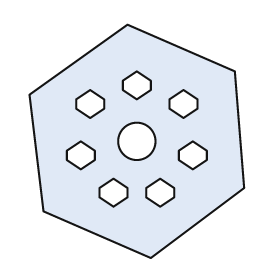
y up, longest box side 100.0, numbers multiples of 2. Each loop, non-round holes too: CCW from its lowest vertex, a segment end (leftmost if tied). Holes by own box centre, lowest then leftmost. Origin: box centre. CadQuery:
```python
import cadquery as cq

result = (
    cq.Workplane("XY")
    .moveTo(6.0, -50.0)
    .lineTo(46.0, -20.0)
    .lineTo(42.0, 30.0)
    .lineTo(-4.0, 50.0)
    .lineTo(-46.0, 20.0)
    .lineTo(-40.0, -30.0)
    .close()
    .moveTo(-10.0, -28.0)
    .lineTo(-4.0, -24.0)
    .lineTo(-4.0, -20.0)
    .lineTo(-10.0, -16.0)
    .lineTo(-16.0, -20.0)
    .lineTo(-16.0, -24.0)
    .close()
    .moveTo(10.0, -28.0)
    .lineTo(16.0, -24.0)
    .lineTo(16.0, -20.0)
    .lineTo(10.0, -16.0)
    .lineTo(4.0, -20.0)
    .lineTo(4.0, -24.0)
    .close()
    .moveTo(-24.0, -12.0)
    .lineTo(-18.0, -8.0)
    .lineTo(-18.0, -4.0)
    .lineTo(-24.0, 0.0)
    .lineTo(-30.0, -4.0)
    .lineTo(-30.0, -8.0)
    .close()
    .moveTo(24.0, -12.0)
    .lineTo(30.0, -8.0)
    .lineTo(30.0, -4.0)
    .lineTo(24.0, 0.0)
    .lineTo(18.0, -4.0)
    .lineTo(18.0, -8.0)
    .close()
    .moveTo(0.0, 0.0)
    .circle(8.0)
    .moveTo(-20.0, 10.0)
    .lineTo(-14.0, 14.0)
    .lineTo(-14.0, 18.0)
    .lineTo(-20.0, 22.0)
    .lineTo(-26.0, 18.0)
    .lineTo(-26.0, 14.0)
    .close()
    .moveTo(20.0, 10.0)
    .lineTo(26.0, 14.0)
    .lineTo(26.0, 18.0)
    .lineTo(20.0, 22.0)
    .lineTo(14.0, 18.0)
    .lineTo(14.0, 14.0)
    .close()
    .moveTo(0.0, 18.0)
    .lineTo(6.0, 22.0)
    .lineTo(6.0, 26.0)
    .lineTo(0.0, 30.0)
    .lineTo(-6.0, 26.0)
    .lineTo(-6.0, 22.0)
    .close()
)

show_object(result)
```